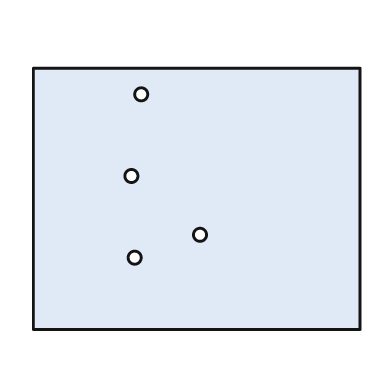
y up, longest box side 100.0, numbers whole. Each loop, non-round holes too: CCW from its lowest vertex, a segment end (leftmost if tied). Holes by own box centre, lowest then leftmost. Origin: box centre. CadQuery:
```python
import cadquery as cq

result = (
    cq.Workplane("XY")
    .moveTo(-50.0, -40.0)
    .lineTo(50.0, -40.0)
    .lineTo(50.0, 40.0)
    .lineTo(-50.0, 40.0)
    .close()
    .moveTo(-19.0, -18.0)
    .circle(2.0)
    .moveTo(1.0, -11.0)
    .circle(2.0)
    .moveTo(-20.0, 7.0)
    .circle(2.0)
    .moveTo(-17.0, 32.0)
    .circle(2.0)
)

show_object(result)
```